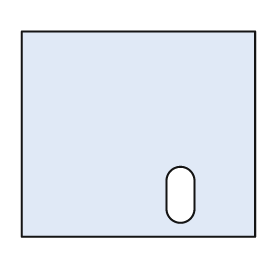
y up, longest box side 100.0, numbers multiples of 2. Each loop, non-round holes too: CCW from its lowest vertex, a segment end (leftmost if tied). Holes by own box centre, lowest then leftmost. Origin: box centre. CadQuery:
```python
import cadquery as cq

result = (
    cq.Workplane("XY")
    .moveTo(-50.0, -44.0)
    .lineTo(50.0, -44.0)
    .lineTo(50.0, 44.0)
    .lineTo(-50.0, 44.0)
    .close()
    .moveTo(12.0, -32.0)
    .threePointArc((18.0, -38.0), (24.0, -32.0))
    .lineTo(24.0, -20.0)
    .threePointArc((18.0, -14.0), (12.0, -20.0))
    .close()
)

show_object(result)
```